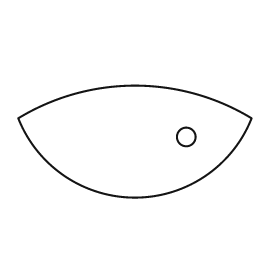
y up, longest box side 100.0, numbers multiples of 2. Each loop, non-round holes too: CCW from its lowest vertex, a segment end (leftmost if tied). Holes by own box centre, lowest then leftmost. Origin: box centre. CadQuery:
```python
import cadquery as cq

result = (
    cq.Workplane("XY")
    .moveTo(-50.0, 10.0)
    .threePointArc((0.0, -24.0), (50.0, 10.0))
    .threePointArc((0.0, 24.0), (-50.0, 10.0))
    .close()
    .moveTo(22.0, 2.0)
    .circle(4.0)
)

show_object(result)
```